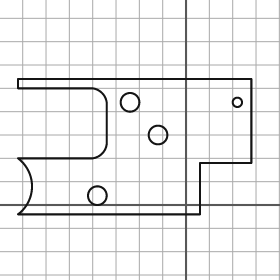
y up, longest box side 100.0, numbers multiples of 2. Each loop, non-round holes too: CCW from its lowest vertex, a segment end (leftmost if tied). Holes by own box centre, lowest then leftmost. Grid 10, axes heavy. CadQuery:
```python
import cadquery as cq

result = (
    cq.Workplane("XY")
    .moveTo(-72.0, -4.0)
    .lineTo(6.0, -4.0)
    .lineTo(6.0, 18.0)
    .lineTo(28.0, 18.0)
    .lineTo(28.0, 54.0)
    .lineTo(-72.0, 54.0)
    .lineTo(-72.0, 50.0)
    .lineTo(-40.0, 50.0)
    .threePointArc((-36.0, 48.0), (-34.0, 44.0))
    .lineTo(-34.0, 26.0)
    .threePointArc((-36.0, 22.0), (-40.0, 20.0))
    .lineTo(-72.0, 20.0)
    .threePointArc((-66.0, 8.0), (-72.0, -4.0))
    .close()
    .moveTo(-38.0, 4.0)
    .circle(4.0)
    .moveTo(-12.0, 30.0)
    .circle(4.0)
    .moveTo(-24.0, 44.0)
    .circle(4.0)
    .moveTo(22.0, 44.0)
    .circle(2.0)
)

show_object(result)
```